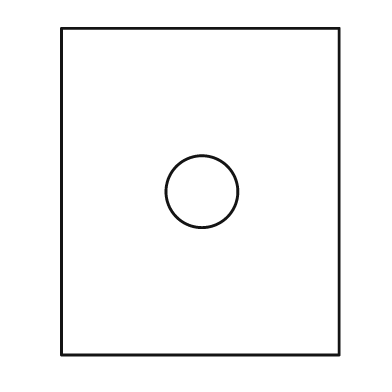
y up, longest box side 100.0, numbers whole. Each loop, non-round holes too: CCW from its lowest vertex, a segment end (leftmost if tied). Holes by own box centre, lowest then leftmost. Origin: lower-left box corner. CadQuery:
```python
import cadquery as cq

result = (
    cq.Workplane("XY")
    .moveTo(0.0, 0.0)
    .lineTo(85.0, 0.0)
    .lineTo(85.0, 100.0)
    .lineTo(0.0, 100.0)
    .close()
    .moveTo(43.0, 50.0)
    .circle(11.0)
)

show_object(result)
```